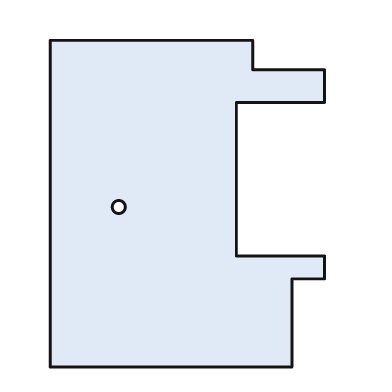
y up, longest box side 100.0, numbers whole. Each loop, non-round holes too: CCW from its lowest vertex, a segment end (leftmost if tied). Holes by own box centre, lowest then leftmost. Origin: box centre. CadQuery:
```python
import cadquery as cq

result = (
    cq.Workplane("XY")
    .moveTo(-42.0, -50.0)
    .lineTo(32.0, -50.0)
    .lineTo(32.0, -23.0)
    .lineTo(42.0, -23.0)
    .lineTo(42.0, -16.0)
    .lineTo(15.0, -16.0)
    .lineTo(15.0, 31.0)
    .lineTo(42.0, 31.0)
    .lineTo(42.0, 41.0)
    .lineTo(20.0, 41.0)
    .lineTo(20.0, 50.0)
    .lineTo(-42.0, 50.0)
    .close()
    .moveTo(-21.0, -1.0)
    .circle(2.0)
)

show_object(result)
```